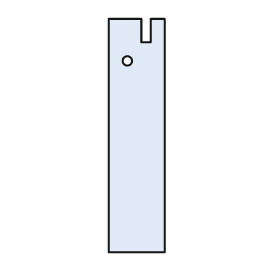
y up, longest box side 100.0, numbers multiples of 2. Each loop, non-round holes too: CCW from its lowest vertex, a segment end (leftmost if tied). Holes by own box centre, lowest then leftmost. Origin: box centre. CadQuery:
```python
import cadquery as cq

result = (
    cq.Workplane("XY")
    .moveTo(-12.0, -50.0)
    .lineTo(12.0, -50.0)
    .lineTo(12.0, 50.0)
    .lineTo(6.0, 50.0)
    .lineTo(6.0, 40.0)
    .lineTo(2.0, 40.0)
    .lineTo(2.0, 50.0)
    .lineTo(-12.0, 50.0)
    .close()
    .moveTo(-4.0, 32.0)
    .circle(2.0)
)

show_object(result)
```